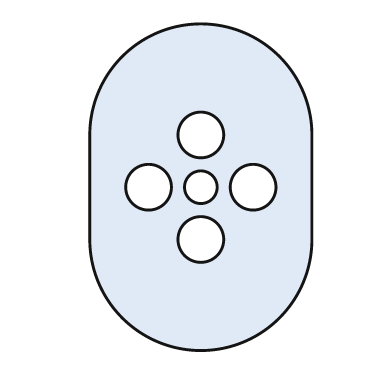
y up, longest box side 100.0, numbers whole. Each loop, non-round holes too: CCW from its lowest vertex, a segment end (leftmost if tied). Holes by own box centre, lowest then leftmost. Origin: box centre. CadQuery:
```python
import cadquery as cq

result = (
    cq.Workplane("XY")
    .moveTo(-34.0, -16.0)
    .threePointArc((0.0, -50.0), (34.0, -16.0))
    .lineTo(34.0, 16.0)
    .threePointArc((0.0, 50.0), (-34.0, 16.0))
    .close()
    .moveTo(0.0, -16.0)
    .circle(7.0)
    .moveTo(-16.0, 0.0)
    .circle(7.0)
    .moveTo(0.0, 0.0)
    .circle(5.0)
    .moveTo(16.0, 0.0)
    .circle(7.0)
    .moveTo(0.0, 16.0)
    .circle(7.0)
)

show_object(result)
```